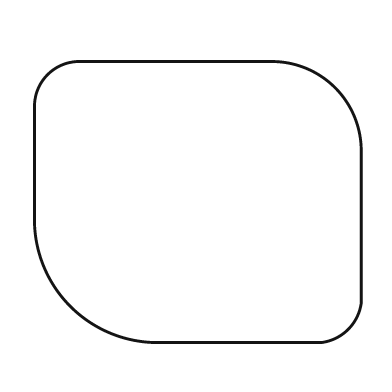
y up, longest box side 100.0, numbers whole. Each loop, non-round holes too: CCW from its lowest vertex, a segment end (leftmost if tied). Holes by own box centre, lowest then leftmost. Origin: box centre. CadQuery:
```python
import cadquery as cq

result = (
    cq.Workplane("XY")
    .moveTo(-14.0, -43.0)
    .lineTo(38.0, -43.0)
    .threePointArc((46.0, -39.0), (50.0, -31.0))
    .lineTo(50.0, 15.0)
    .threePointArc((42.0, 35.0), (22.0, 43.0))
    .lineTo(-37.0, 43.0)
    .threePointArc((-46.0, 39.0), (-50.0, 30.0))
    .lineTo(-50.0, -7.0)
    .threePointArc((-39.0, -32.0), (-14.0, -43.0))
    .close()
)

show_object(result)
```